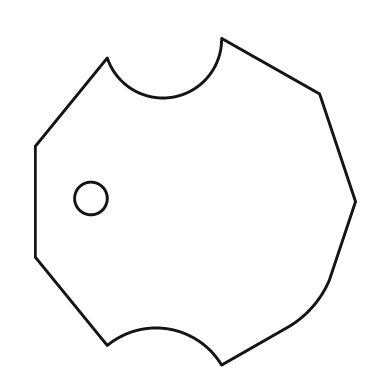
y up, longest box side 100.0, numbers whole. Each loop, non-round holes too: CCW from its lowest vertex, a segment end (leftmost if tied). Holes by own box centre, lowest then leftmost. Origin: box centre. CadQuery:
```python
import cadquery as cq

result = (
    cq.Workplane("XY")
    .moveTo(8.0, -50.0)
    .lineTo(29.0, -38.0)
    .threePointArc((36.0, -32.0), (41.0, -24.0))
    .lineTo(49.0, 0.0)
    .lineTo(38.0, 33.0)
    .lineTo(8.0, 50.0)
    .threePointArc((-7.0, 32.0), (-27.0, 44.0))
    .lineTo(-49.0, 17.0)
    .lineTo(-49.0, -17.0)
    .lineTo(-27.0, -44.0)
    .threePointArc((-8.0, -39.0), (8.0, -50.0))
    .close()
    .moveTo(-32.0, 1.0)
    .circle(5.0)
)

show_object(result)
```